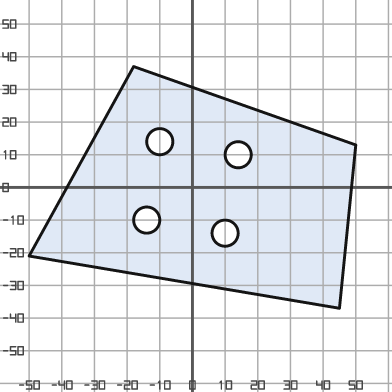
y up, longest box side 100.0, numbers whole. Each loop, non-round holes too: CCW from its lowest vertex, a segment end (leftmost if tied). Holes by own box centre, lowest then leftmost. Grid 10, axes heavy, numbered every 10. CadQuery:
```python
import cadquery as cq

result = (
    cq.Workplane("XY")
    .moveTo(45.0, -37.0)
    .lineTo(50.0, 13.0)
    .lineTo(-18.0, 37.0)
    .lineTo(-50.0, -21.0)
    .close()
    .moveTo(10.0, -14.0)
    .circle(4.0)
    .moveTo(-14.0, -10.0)
    .circle(4.0)
    .moveTo(14.0, 10.0)
    .circle(4.0)
    .moveTo(-10.0, 14.0)
    .circle(4.0)
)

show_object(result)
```